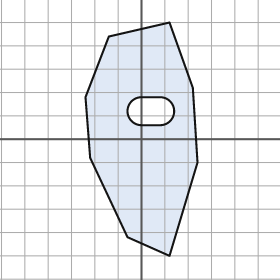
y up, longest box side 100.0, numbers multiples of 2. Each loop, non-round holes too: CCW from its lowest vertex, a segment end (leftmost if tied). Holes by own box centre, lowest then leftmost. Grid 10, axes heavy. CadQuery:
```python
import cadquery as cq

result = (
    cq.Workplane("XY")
    .moveTo(12.0, -50.0)
    .lineTo(24.0, -10.0)
    .lineTo(22.0, 22.0)
    .lineTo(12.0, 50.0)
    .lineTo(-14.0, 44.0)
    .lineTo(-24.0, 18.0)
    .lineTo(-22.0, -8.0)
    .lineTo(-6.0, -42.0)
    .close()
    .moveTo(0.0, 6.0)
    .lineTo(8.0, 6.0)
    .threePointArc((14.0, 12.0), (8.0, 18.0))
    .lineTo(0.0, 18.0)
    .threePointArc((-6.0, 12.0), (0.0, 6.0))
    .close()
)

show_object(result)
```